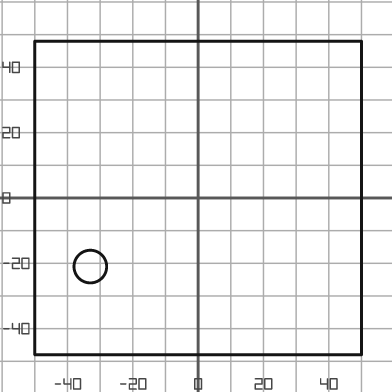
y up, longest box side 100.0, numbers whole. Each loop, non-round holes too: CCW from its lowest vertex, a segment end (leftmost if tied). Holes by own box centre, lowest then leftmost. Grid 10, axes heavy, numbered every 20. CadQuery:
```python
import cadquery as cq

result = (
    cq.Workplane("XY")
    .moveTo(-50.0, -48.0)
    .lineTo(50.0, -48.0)
    .lineTo(50.0, 48.0)
    .lineTo(-50.0, 48.0)
    .close()
    .moveTo(-33.0, -21.0)
    .circle(5.0)
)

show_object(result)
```